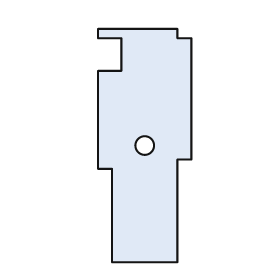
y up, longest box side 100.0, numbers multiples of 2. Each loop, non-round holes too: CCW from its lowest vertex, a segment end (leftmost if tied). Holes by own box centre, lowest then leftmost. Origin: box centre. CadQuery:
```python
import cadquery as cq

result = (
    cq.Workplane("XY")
    .moveTo(-14.0, -50.0)
    .lineTo(14.0, -50.0)
    .lineTo(14.0, -6.0)
    .lineTo(20.0, -6.0)
    .lineTo(20.0, 46.0)
    .lineTo(14.0, 46.0)
    .lineTo(14.0, 50.0)
    .lineTo(-20.0, 50.0)
    .lineTo(-20.0, 46.0)
    .lineTo(-10.0, 46.0)
    .lineTo(-10.0, 32.0)
    .lineTo(-20.0, 32.0)
    .lineTo(-20.0, -10.0)
    .lineTo(-14.0, -10.0)
    .close()
    .moveTo(0.0, 0.0)
    .circle(4.0)
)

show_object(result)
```